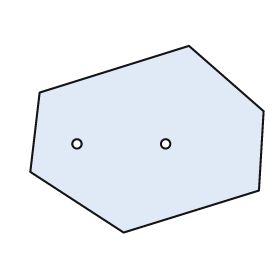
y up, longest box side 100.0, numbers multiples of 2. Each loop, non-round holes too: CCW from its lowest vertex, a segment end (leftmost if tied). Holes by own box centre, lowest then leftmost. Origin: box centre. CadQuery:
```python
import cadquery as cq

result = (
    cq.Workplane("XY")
    .moveTo(-10.0, -40.0)
    .lineTo(48.0, -22.0)
    .lineTo(50.0, 12.0)
    .lineTo(18.0, 40.0)
    .lineTo(-46.0, 20.0)
    .lineTo(-50.0, -14.0)
    .close()
    .moveTo(-30.0, -2.0)
    .circle(2.0)
    .moveTo(8.0, -2.0)
    .circle(2.0)
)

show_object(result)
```